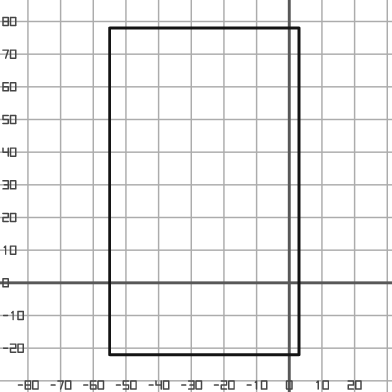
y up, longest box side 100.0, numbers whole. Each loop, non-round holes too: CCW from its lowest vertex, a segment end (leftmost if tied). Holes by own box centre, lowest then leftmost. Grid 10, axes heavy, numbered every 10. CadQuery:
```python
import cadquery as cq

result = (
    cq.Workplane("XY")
    .moveTo(-55.0, -22.0)
    .lineTo(3.0, -22.0)
    .lineTo(3.0, 78.0)
    .lineTo(-55.0, 78.0)
    .close()
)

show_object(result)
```